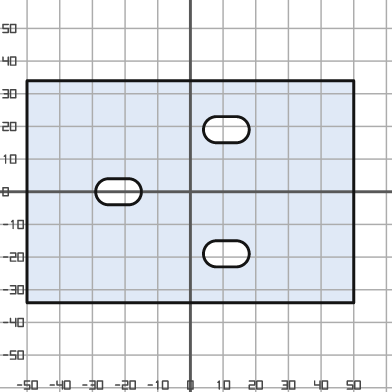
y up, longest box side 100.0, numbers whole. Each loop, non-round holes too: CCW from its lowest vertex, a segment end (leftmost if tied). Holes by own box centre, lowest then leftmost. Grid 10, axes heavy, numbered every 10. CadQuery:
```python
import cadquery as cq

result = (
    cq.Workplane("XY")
    .moveTo(-50.0, -34.0)
    .lineTo(50.0, -34.0)
    .lineTo(50.0, 34.0)
    .lineTo(-50.0, 34.0)
    .close()
    .moveTo(8.0, -23.0)
    .lineTo(14.0, -23.0)
    .threePointArc((18.0, -19.0), (14.0, -15.0))
    .lineTo(8.0, -15.0)
    .threePointArc((4.0, -19.0), (8.0, -23.0))
    .close()
    .moveTo(-25.0, -4.0)
    .lineTo(-19.0, -4.0)
    .threePointArc((-15.0, 0.0), (-19.0, 4.0))
    .lineTo(-25.0, 4.0)
    .threePointArc((-29.0, 0.0), (-25.0, -4.0))
    .close()
    .moveTo(8.0, 15.0)
    .lineTo(14.0, 15.0)
    .threePointArc((18.0, 19.0), (14.0, 23.0))
    .lineTo(8.0, 23.0)
    .threePointArc((4.0, 19.0), (8.0, 15.0))
    .close()
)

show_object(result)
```